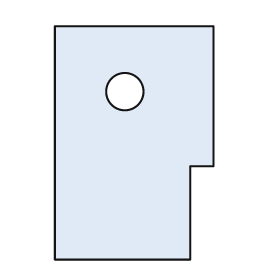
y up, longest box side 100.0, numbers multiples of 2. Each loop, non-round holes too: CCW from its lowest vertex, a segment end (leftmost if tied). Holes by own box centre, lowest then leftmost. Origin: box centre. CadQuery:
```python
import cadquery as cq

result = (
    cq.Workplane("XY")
    .moveTo(-34.0, -50.0)
    .lineTo(24.0, -50.0)
    .lineTo(24.0, -10.0)
    .lineTo(34.0, -10.0)
    .lineTo(34.0, 50.0)
    .lineTo(-34.0, 50.0)
    .close()
    .moveTo(-4.0, 22.0)
    .circle(8.0)
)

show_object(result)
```